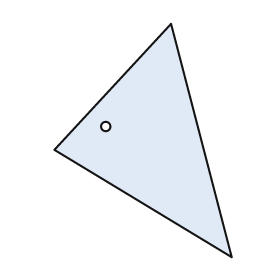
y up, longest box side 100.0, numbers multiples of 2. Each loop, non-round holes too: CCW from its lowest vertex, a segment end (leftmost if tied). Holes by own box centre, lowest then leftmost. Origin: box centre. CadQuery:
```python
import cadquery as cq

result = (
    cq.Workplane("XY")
    .moveTo(38.0, -50.0)
    .lineTo(12.0, 50.0)
    .lineTo(-38.0, -4.0)
    .close()
    .moveTo(-16.0, 6.0)
    .circle(2.0)
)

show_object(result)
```